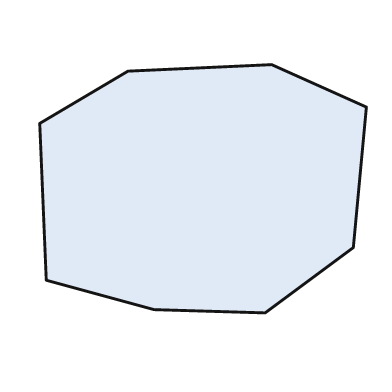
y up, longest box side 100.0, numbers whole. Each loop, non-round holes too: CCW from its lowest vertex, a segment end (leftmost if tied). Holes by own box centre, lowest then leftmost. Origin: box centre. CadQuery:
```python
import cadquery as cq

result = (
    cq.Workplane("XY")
    .moveTo(19.0, -38.0)
    .lineTo(46.0, -18.0)
    .lineTo(50.0, 25.0)
    .lineTo(21.0, 38.0)
    .lineTo(-23.0, 36.0)
    .lineTo(-50.0, 20.0)
    .lineTo(-48.0, -28.0)
    .lineTo(-15.0, -37.0)
    .close()
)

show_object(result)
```